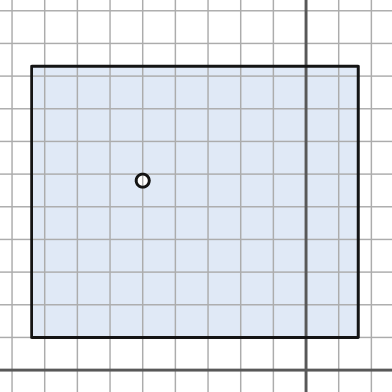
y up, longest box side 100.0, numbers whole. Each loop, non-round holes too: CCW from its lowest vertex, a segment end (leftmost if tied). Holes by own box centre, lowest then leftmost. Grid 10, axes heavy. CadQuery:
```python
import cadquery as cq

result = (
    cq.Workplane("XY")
    .moveTo(-84.0, 10.0)
    .lineTo(16.0, 10.0)
    .lineTo(16.0, 93.0)
    .lineTo(-84.0, 93.0)
    .close()
    .moveTo(-50.0, 58.0)
    .circle(2.0)
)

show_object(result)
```